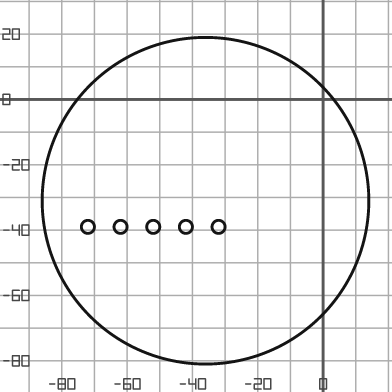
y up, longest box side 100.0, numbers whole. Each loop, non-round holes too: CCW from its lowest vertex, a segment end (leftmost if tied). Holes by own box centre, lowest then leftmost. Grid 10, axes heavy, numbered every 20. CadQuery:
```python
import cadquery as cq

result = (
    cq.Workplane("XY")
    .moveTo(-36.0, -31.0)
    .circle(50.0)
    .moveTo(-72.0, -39.0)
    .circle(2.0)
    .moveTo(-62.0, -39.0)
    .circle(2.0)
    .moveTo(-52.0, -39.0)
    .circle(2.0)
    .moveTo(-42.0, -39.0)
    .circle(2.0)
    .moveTo(-32.0, -39.0)
    .circle(2.0)
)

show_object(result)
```